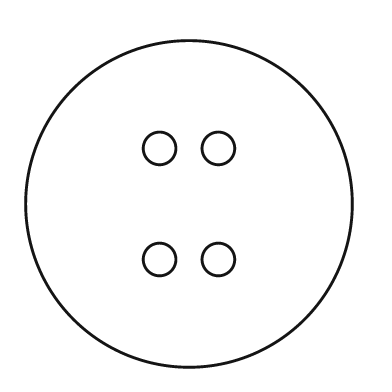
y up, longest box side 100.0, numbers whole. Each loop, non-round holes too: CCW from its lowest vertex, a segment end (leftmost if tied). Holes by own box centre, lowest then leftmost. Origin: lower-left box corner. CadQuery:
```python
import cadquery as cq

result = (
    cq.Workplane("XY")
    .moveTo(50.0, 50.0)
    .circle(50.0)
    .moveTo(41.0, 33.0)
    .circle(5.0)
    .moveTo(59.0, 33.0)
    .circle(5.0)
    .moveTo(41.0, 67.0)
    .circle(5.0)
    .moveTo(59.0, 67.0)
    .circle(5.0)
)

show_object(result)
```